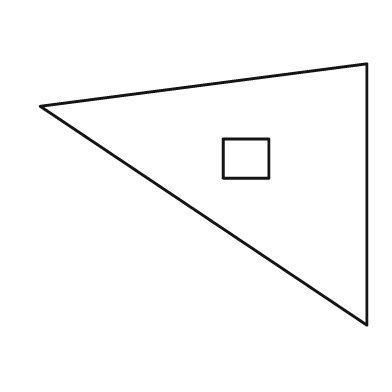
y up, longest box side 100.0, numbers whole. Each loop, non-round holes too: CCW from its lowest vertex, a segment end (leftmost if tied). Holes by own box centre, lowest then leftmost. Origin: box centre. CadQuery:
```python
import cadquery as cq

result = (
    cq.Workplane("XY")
    .moveTo(50.0, -40.0)
    .lineTo(50.0, 40.0)
    .lineTo(-50.0, 27.0)
    .close()
    .moveTo(6.0, 5.0)
    .lineTo(20.0, 5.0)
    .lineTo(20.0, 17.0)
    .lineTo(6.0, 17.0)
    .close()
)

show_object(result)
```